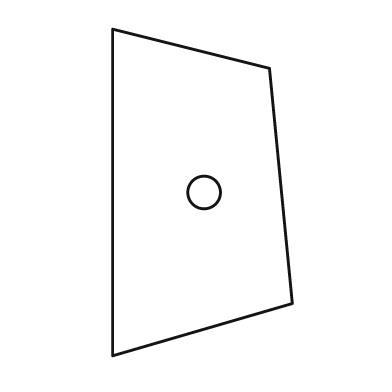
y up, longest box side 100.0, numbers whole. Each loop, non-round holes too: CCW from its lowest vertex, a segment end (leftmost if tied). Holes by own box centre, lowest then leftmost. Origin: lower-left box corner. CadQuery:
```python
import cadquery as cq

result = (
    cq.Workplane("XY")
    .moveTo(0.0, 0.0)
    .lineTo(55.0, 16.0)
    .lineTo(48.0, 88.0)
    .lineTo(0.0, 100.0)
    .close()
    .moveTo(28.0, 50.0)
    .circle(5.0)
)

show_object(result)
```